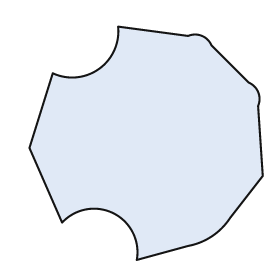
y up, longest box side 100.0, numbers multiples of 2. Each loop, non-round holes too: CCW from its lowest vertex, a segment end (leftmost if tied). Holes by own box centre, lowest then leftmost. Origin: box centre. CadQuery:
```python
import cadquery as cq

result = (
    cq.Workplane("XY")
    .moveTo(-4.0, -50.0)
    .lineTo(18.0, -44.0)
    .threePointArc((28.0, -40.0), (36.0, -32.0))
    .lineTo(50.0, -14.0)
    .lineTo(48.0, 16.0)
    .threePointArc((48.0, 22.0), (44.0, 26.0))
    .lineTo(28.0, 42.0)
    .threePointArc((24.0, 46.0), (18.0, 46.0))
    .lineTo(-12.0, 50.0)
    .threePointArc((-20.0, 32.0), (-40.0, 30.0))
    .lineTo(-50.0, -2.0)
    .lineTo(-36.0, -34.0)
    .threePointArc((-14.0, -30.0), (-4.0, -50.0))
    .close()
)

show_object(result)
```